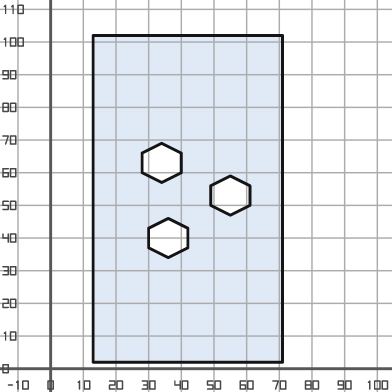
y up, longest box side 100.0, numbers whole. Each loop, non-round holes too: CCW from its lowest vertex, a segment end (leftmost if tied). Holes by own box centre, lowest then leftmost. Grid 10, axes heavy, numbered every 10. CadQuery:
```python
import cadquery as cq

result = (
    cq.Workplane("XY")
    .moveTo(13.0, 2.0)
    .lineTo(71.0, 2.0)
    .lineTo(71.0, 102.0)
    .lineTo(13.0, 102.0)
    .close()
    .moveTo(36.0, 34.0)
    .lineTo(42.0, 37.0)
    .lineTo(42.0, 43.0)
    .lineTo(36.0, 46.0)
    .lineTo(30.0, 43.0)
    .lineTo(30.0, 37.0)
    .close()
    .moveTo(55.0, 47.0)
    .lineTo(61.0, 50.0)
    .lineTo(61.0, 56.0)
    .lineTo(55.0, 59.0)
    .lineTo(49.0, 56.0)
    .lineTo(49.0, 50.0)
    .close()
    .moveTo(34.0, 57.0)
    .lineTo(40.0, 60.0)
    .lineTo(40.0, 66.0)
    .lineTo(34.0, 69.0)
    .lineTo(28.0, 66.0)
    .lineTo(28.0, 60.0)
    .close()
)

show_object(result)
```